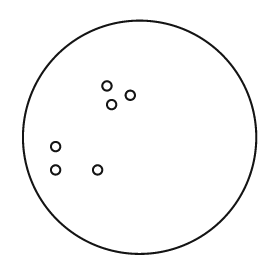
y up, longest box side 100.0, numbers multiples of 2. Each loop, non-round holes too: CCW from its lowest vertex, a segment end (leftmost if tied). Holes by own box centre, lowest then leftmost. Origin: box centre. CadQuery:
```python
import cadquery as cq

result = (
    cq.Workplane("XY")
    .moveTo(0.0, 0.0)
    .circle(50.0)
    .moveTo(-36.0, -14.0)
    .circle(2.0)
    .moveTo(-18.0, -14.0)
    .circle(2.0)
    .moveTo(-36.0, -4.0)
    .circle(2.0)
    .moveTo(-12.0, 14.0)
    .circle(2.0)
    .moveTo(-4.0, 18.0)
    .circle(2.0)
    .moveTo(-14.0, 22.0)
    .circle(2.0)
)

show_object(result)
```